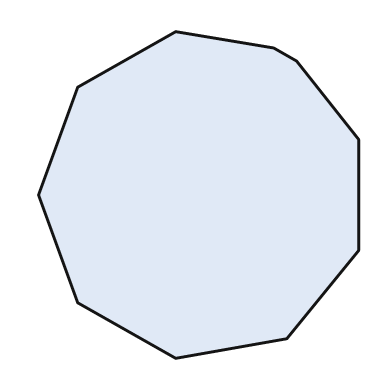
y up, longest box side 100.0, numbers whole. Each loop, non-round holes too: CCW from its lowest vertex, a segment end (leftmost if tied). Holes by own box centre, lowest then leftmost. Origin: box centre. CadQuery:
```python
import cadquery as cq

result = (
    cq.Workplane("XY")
    .moveTo(-7.0, -50.0)
    .lineTo(27.0, -44.0)
    .lineTo(49.0, -17.0)
    .lineTo(49.0, 17.0)
    .lineTo(30.0, 41.0)
    .lineTo(23.0, 45.0)
    .lineTo(-7.0, 50.0)
    .lineTo(-37.0, 33.0)
    .lineTo(-49.0, 0.0)
    .lineTo(-37.0, -33.0)
    .close()
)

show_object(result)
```